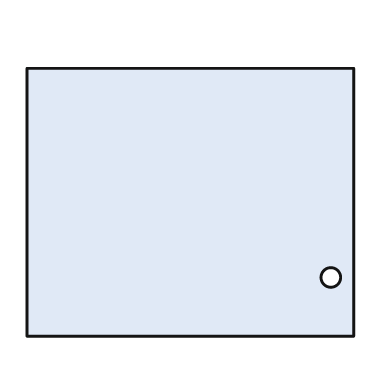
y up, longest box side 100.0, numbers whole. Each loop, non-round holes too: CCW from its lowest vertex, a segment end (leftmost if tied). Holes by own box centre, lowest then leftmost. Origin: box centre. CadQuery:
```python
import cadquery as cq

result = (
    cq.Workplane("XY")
    .moveTo(-50.0, -41.0)
    .lineTo(50.0, -41.0)
    .lineTo(50.0, 41.0)
    .lineTo(-50.0, 41.0)
    .close()
    .moveTo(43.0, -23.0)
    .circle(3.0)
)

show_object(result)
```